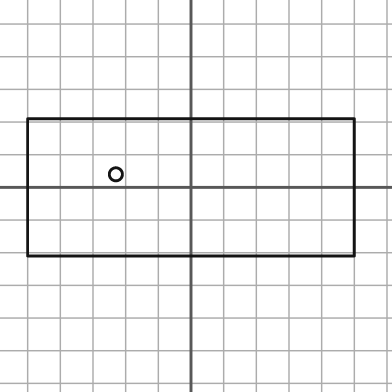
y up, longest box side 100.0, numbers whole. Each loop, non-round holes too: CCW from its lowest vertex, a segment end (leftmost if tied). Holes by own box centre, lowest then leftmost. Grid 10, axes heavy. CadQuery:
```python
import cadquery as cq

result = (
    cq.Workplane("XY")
    .moveTo(-50.0, -21.0)
    .lineTo(50.0, -21.0)
    .lineTo(50.0, 21.0)
    .lineTo(-50.0, 21.0)
    .close()
    .moveTo(-23.0, 4.0)
    .circle(2.0)
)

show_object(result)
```